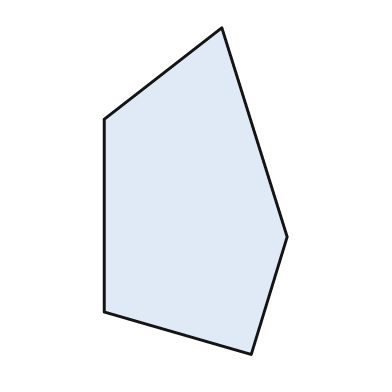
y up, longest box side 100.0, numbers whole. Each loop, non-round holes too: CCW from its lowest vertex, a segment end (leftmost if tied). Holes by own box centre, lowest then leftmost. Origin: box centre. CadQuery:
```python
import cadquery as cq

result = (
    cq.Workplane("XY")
    .moveTo(17.0, -50.0)
    .lineTo(28.0, -14.0)
    .lineTo(8.0, 50.0)
    .lineTo(-28.0, 22.0)
    .lineTo(-28.0, -37.0)
    .close()
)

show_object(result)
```